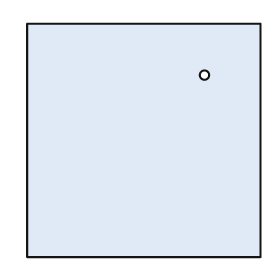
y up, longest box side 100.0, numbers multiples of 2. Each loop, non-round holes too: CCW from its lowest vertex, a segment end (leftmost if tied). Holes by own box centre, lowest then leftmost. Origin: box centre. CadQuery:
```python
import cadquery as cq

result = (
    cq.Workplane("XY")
    .moveTo(-50.0, -50.0)
    .lineTo(50.0, -50.0)
    .lineTo(50.0, 50.0)
    .lineTo(-50.0, 50.0)
    .close()
    .moveTo(26.0, 28.0)
    .circle(2.0)
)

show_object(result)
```